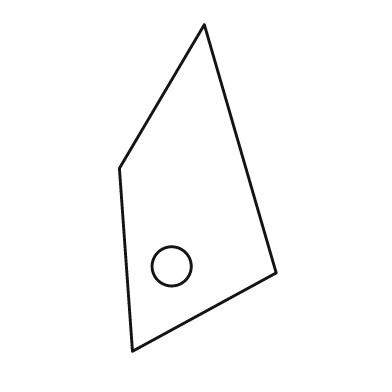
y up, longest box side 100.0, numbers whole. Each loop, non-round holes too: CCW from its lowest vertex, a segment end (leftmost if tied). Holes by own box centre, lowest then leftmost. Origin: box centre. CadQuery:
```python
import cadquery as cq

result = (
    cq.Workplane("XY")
    .moveTo(-20.0, -50.0)
    .lineTo(24.0, -26.0)
    .lineTo(2.0, 50.0)
    .lineTo(-24.0, 6.0)
    .close()
    .moveTo(-8.0, -24.0)
    .circle(6.0)
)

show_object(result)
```